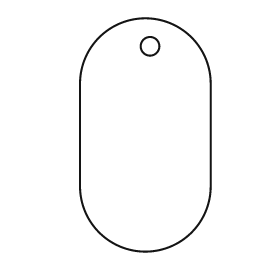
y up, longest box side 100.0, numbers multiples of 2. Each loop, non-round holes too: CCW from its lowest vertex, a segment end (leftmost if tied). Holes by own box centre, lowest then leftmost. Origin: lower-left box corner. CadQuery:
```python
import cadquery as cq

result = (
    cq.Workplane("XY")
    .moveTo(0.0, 28.0)
    .threePointArc((28.0, 0.0), (56.0, 28.0))
    .lineTo(56.0, 72.0)
    .threePointArc((28.0, 100.0), (0.0, 72.0))
    .close()
    .moveTo(30.0, 88.0)
    .circle(4.0)
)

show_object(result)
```